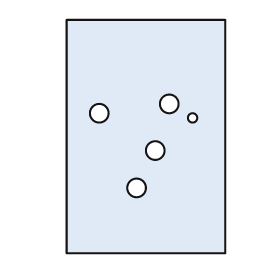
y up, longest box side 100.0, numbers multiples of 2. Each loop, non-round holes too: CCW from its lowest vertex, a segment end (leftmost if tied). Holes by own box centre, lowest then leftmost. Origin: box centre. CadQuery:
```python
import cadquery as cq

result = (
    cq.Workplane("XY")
    .moveTo(-34.0, -50.0)
    .lineTo(34.0, -50.0)
    .lineTo(34.0, 50.0)
    .lineTo(-34.0, 50.0)
    .close()
    .moveTo(-4.0, -22.0)
    .circle(4.0)
    .moveTo(4.0, -6.0)
    .circle(4.0)
    .moveTo(20.0, 8.0)
    .circle(2.0)
    .moveTo(-20.0, 10.0)
    .circle(4.0)
    .moveTo(10.0, 14.0)
    .circle(4.0)
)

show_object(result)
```